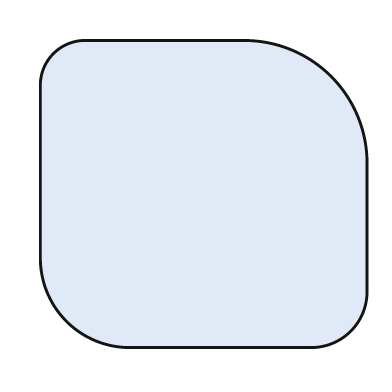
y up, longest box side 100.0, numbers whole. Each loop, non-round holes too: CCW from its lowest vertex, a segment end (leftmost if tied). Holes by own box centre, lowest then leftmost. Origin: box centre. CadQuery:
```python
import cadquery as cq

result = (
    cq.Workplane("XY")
    .moveTo(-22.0, -47.0)
    .lineTo(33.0, -47.0)
    .threePointArc((45.0, -42.0), (50.0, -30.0))
    .lineTo(50.0, 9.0)
    .threePointArc((39.0, 36.0), (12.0, 47.0))
    .lineTo(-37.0, 47.0)
    .threePointArc((-46.0, 43.0), (-50.0, 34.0))
    .lineTo(-50.0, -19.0)
    .threePointArc((-42.0, -39.0), (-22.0, -47.0))
    .close()
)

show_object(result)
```